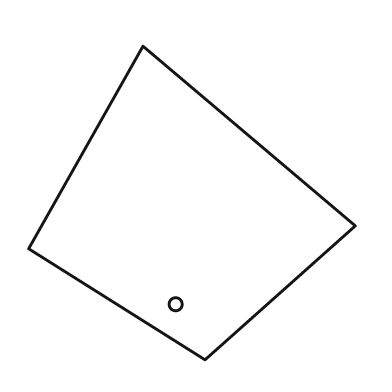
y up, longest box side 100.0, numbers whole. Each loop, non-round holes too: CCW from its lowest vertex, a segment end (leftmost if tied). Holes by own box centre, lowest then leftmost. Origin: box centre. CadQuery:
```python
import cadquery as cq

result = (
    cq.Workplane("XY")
    .moveTo(4.0, -48.0)
    .lineTo(50.0, -7.0)
    .lineTo(-15.0, 48.0)
    .lineTo(-50.0, -14.0)
    .close()
    .moveTo(-5.0, -31.0)
    .circle(2.0)
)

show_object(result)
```